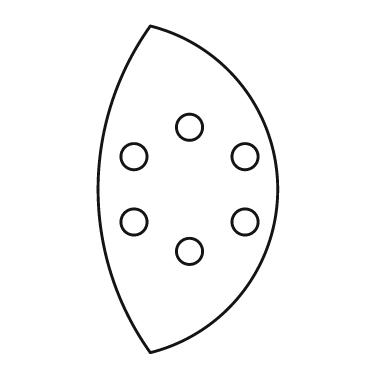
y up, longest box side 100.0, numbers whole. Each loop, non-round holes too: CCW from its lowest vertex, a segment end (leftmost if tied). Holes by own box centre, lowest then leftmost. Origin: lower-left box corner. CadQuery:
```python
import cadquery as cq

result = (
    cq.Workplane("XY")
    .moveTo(16.0, 0.0)
    .threePointArc((55.0, 50.0), (16.0, 100.0))
    .threePointArc((0.0, 50.0), (16.0, 0.0))
    .close()
    .moveTo(28.0, 31.0)
    .circle(4.0)
    .moveTo(11.0, 40.0)
    .circle(4.0)
    .moveTo(45.0, 40.0)
    .circle(4.0)
    .moveTo(11.0, 60.0)
    .circle(4.0)
    .moveTo(45.0, 60.0)
    .circle(4.0)
    .moveTo(28.0, 69.0)
    .circle(4.0)
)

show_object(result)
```